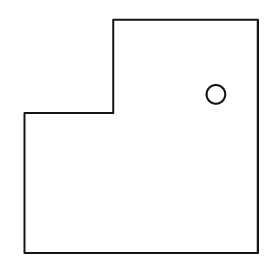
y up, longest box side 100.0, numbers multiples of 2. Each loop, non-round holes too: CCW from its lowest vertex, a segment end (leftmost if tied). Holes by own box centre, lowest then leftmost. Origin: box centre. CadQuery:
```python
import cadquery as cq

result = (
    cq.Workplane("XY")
    .moveTo(-50.0, -50.0)
    .lineTo(50.0, -50.0)
    .lineTo(50.0, 50.0)
    .lineTo(-12.0, 50.0)
    .lineTo(-12.0, 10.0)
    .lineTo(-50.0, 10.0)
    .close()
    .moveTo(32.0, 18.0)
    .circle(4.0)
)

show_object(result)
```